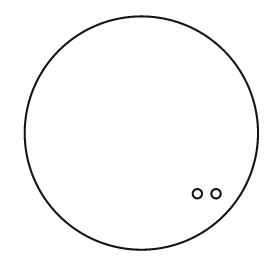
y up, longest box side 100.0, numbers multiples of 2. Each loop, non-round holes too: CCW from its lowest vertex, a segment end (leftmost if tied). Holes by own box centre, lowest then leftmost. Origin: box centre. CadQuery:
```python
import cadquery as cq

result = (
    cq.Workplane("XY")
    .moveTo(0.0, 0.0)
    .circle(50.0)
    .moveTo(24.0, -26.0)
    .circle(2.0)
    .moveTo(32.0, -26.0)
    .circle(2.0)
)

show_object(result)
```